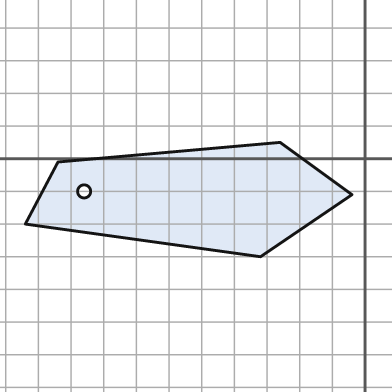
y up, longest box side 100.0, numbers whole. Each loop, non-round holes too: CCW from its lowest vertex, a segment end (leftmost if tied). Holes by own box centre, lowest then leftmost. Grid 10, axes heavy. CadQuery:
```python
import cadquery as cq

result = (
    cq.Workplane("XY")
    .moveTo(-32.0, -30.0)
    .lineTo(-4.0, -11.0)
    .lineTo(-26.0, 5.0)
    .lineTo(-94.0, -1.0)
    .lineTo(-104.0, -20.0)
    .close()
    .moveTo(-86.0, -10.0)
    .circle(2.0)
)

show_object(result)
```